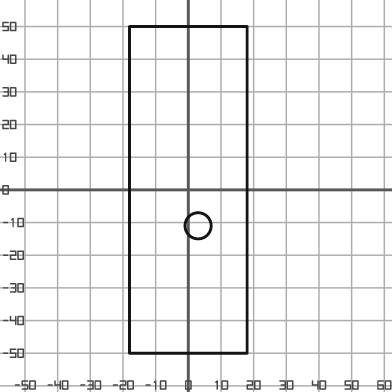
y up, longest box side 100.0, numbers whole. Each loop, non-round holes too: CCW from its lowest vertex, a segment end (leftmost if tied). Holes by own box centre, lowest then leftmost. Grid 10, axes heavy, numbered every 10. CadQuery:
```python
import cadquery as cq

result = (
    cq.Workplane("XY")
    .moveTo(-18.0, -50.0)
    .lineTo(18.0, -50.0)
    .lineTo(18.0, 50.0)
    .lineTo(-18.0, 50.0)
    .close()
    .moveTo(3.0, -11.0)
    .circle(4.0)
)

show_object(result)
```